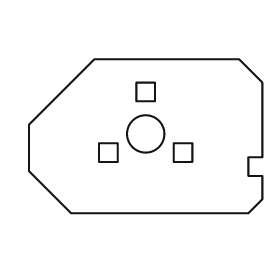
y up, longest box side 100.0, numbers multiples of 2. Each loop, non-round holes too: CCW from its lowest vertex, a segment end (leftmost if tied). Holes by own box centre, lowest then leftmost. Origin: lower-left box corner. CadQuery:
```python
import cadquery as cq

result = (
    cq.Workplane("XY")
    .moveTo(18.0, 0.0)
    .lineTo(94.0, 0.0)
    .lineTo(100.0, 6.0)
    .lineTo(100.0, 16.0)
    .lineTo(94.0, 16.0)
    .lineTo(94.0, 24.0)
    .lineTo(100.0, 24.0)
    .lineTo(100.0, 56.0)
    .lineTo(90.0, 66.0)
    .lineTo(28.0, 66.0)
    .lineTo(0.0, 38.0)
    .lineTo(0.0, 18.0)
    .close()
    .moveTo(30.0, 22.0)
    .lineTo(38.0, 22.0)
    .lineTo(38.0, 30.0)
    .lineTo(30.0, 30.0)
    .close()
    .moveTo(62.0, 22.0)
    .lineTo(70.0, 22.0)
    .lineTo(70.0, 30.0)
    .lineTo(62.0, 30.0)
    .close()
    .moveTo(50.0, 34.0)
    .circle(8.0)
    .moveTo(46.0, 48.0)
    .lineTo(54.0, 48.0)
    .lineTo(54.0, 56.0)
    .lineTo(46.0, 56.0)
    .close()
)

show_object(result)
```